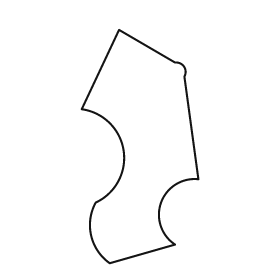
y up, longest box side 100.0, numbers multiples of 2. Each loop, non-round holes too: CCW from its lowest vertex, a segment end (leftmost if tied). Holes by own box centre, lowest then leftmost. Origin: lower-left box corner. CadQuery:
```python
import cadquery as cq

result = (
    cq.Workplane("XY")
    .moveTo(12.0, 0.0)
    .lineTo(40.0, 8.0)
    .threePointArc((34.0, 26.0), (50.0, 36.0))
    .lineTo(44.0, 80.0)
    .threePointArc((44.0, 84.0), (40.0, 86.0))
    .lineTo(16.0, 100.0)
    .lineTo(0.0, 66.0)
    .threePointArc((18.0, 48.0), (6.0, 26.0))
    .threePointArc((4.0, 12.0), (12.0, 0.0))
    .close()
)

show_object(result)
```